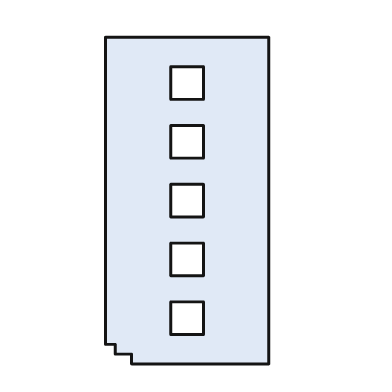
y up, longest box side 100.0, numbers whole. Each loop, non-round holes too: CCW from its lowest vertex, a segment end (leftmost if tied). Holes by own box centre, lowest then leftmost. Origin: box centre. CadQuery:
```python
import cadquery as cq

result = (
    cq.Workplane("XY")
    .moveTo(-17.0, -50.0)
    .lineTo(25.0, -50.0)
    .lineTo(25.0, 50.0)
    .lineTo(-25.0, 50.0)
    .lineTo(-25.0, -44.0)
    .lineTo(-22.0, -44.0)
    .lineTo(-22.0, -47.0)
    .lineTo(-17.0, -47.0)
    .close()
    .moveTo(-5.0, -41.0)
    .lineTo(5.0, -41.0)
    .lineTo(5.0, -31.0)
    .lineTo(-5.0, -31.0)
    .close()
    .moveTo(-5.0, -23.0)
    .lineTo(5.0, -23.0)
    .lineTo(5.0, -13.0)
    .lineTo(-5.0, -13.0)
    .close()
    .moveTo(-5.0, -5.0)
    .lineTo(5.0, -5.0)
    .lineTo(5.0, 5.0)
    .lineTo(-5.0, 5.0)
    .close()
    .moveTo(-5.0, 13.0)
    .lineTo(5.0, 13.0)
    .lineTo(5.0, 23.0)
    .lineTo(-5.0, 23.0)
    .close()
    .moveTo(-5.0, 31.0)
    .lineTo(5.0, 31.0)
    .lineTo(5.0, 41.0)
    .lineTo(-5.0, 41.0)
    .close()
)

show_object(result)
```